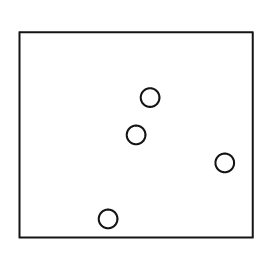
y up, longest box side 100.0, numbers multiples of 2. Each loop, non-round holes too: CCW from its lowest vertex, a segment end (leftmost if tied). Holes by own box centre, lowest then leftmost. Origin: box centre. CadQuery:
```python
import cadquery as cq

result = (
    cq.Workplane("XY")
    .moveTo(-50.0, -44.0)
    .lineTo(50.0, -44.0)
    .lineTo(50.0, 44.0)
    .lineTo(-50.0, 44.0)
    .close()
    .moveTo(-12.0, -36.0)
    .circle(4.0)
    .moveTo(38.0, -12.0)
    .circle(4.0)
    .moveTo(0.0, 0.0)
    .circle(4.0)
    .moveTo(6.0, 16.0)
    .circle(4.0)
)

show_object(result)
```